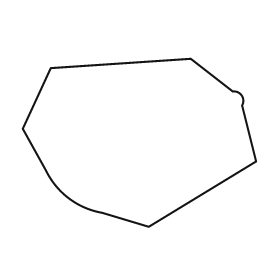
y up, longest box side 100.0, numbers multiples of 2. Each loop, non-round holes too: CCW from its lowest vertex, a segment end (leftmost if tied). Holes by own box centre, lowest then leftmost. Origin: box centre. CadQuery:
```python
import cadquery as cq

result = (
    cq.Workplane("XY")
    .moveTo(4.0, -36.0)
    .lineTo(50.0, -8.0)
    .lineTo(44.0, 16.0)
    .threePointArc((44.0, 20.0), (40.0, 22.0))
    .lineTo(22.0, 36.0)
    .lineTo(-38.0, 32.0)
    .lineTo(-50.0, 6.0)
    .lineTo(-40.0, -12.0)
    .threePointArc((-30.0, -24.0), (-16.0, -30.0))
    .close()
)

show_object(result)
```